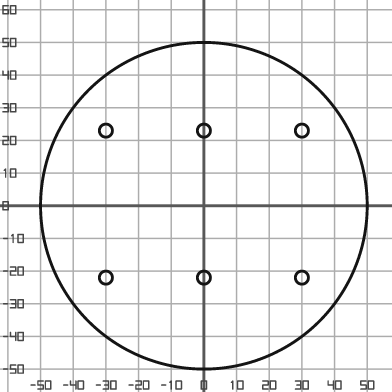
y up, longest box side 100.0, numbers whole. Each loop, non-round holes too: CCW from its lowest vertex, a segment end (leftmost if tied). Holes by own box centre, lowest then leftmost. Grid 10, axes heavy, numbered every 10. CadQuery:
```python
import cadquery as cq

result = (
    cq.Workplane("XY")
    .moveTo(0.0, 0.0)
    .circle(50.0)
    .moveTo(-30.0, -22.0)
    .circle(2.0)
    .moveTo(0.0, -22.0)
    .circle(2.0)
    .moveTo(30.0, -22.0)
    .circle(2.0)
    .moveTo(-30.0, 23.0)
    .circle(2.0)
    .moveTo(0.0, 23.0)
    .circle(2.0)
    .moveTo(30.0, 23.0)
    .circle(2.0)
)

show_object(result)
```